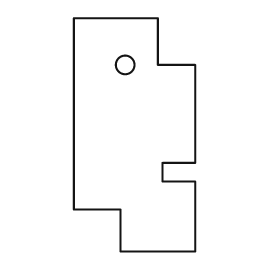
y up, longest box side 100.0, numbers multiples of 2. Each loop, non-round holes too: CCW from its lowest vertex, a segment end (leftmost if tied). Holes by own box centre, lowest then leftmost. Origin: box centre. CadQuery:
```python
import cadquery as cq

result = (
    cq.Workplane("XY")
    .moveTo(-6.0, -50.0)
    .lineTo(26.0, -50.0)
    .lineTo(26.0, -20.0)
    .lineTo(12.0, -20.0)
    .lineTo(12.0, -12.0)
    .lineTo(26.0, -12.0)
    .lineTo(26.0, 30.0)
    .lineTo(10.0, 30.0)
    .lineTo(10.0, 50.0)
    .lineTo(-26.0, 50.0)
    .lineTo(-26.0, -32.0)
    .lineTo(-6.0, -32.0)
    .close()
    .moveTo(-4.0, 30.0)
    .circle(4.0)
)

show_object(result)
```